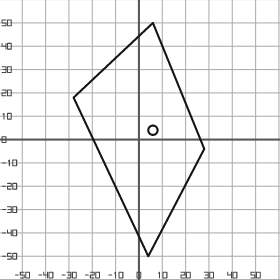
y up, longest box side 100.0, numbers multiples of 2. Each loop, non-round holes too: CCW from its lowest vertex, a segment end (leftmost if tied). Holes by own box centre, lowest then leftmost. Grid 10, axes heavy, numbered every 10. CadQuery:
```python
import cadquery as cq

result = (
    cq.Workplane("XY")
    .moveTo(4.0, -50.0)
    .lineTo(28.0, -4.0)
    .lineTo(6.0, 50.0)
    .lineTo(-28.0, 18.0)
    .close()
    .moveTo(6.0, 4.0)
    .circle(2.0)
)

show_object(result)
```